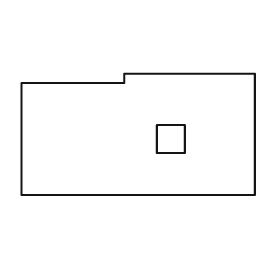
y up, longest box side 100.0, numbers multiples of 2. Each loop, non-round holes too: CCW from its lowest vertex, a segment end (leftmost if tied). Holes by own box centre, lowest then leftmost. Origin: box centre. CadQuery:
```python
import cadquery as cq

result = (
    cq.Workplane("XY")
    .moveTo(-50.0, -26.0)
    .lineTo(50.0, -26.0)
    .lineTo(50.0, 26.0)
    .lineTo(-6.0, 26.0)
    .lineTo(-6.0, 22.0)
    .lineTo(-50.0, 22.0)
    .close()
    .moveTo(8.0, -8.0)
    .lineTo(20.0, -8.0)
    .lineTo(20.0, 4.0)
    .lineTo(8.0, 4.0)
    .close()
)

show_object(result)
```